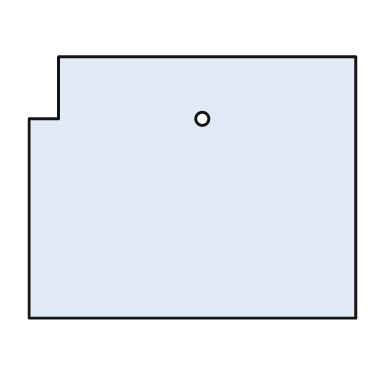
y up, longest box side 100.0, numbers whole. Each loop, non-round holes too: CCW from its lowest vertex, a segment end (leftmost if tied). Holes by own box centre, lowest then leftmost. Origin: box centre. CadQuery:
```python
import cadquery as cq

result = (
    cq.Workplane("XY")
    .moveTo(-50.0, -40.0)
    .lineTo(50.0, -40.0)
    .lineTo(50.0, 40.0)
    .lineTo(-41.0, 40.0)
    .lineTo(-41.0, 21.0)
    .lineTo(-50.0, 21.0)
    .close()
    .moveTo(3.0, 21.0)
    .circle(2.0)
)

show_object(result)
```